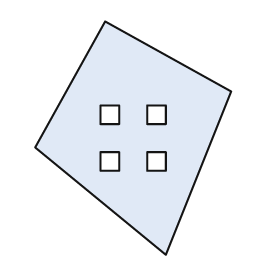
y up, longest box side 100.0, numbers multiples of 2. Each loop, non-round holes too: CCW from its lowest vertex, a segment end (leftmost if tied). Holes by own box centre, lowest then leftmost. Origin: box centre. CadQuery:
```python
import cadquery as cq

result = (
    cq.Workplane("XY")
    .moveTo(14.0, -50.0)
    .lineTo(42.0, 20.0)
    .lineTo(-12.0, 50.0)
    .lineTo(-42.0, -4.0)
    .close()
    .moveTo(-14.0, -14.0)
    .lineTo(-6.0, -14.0)
    .lineTo(-6.0, -6.0)
    .lineTo(-14.0, -6.0)
    .close()
    .moveTo(6.0, -14.0)
    .lineTo(14.0, -14.0)
    .lineTo(14.0, -6.0)
    .lineTo(6.0, -6.0)
    .close()
    .moveTo(-14.0, 6.0)
    .lineTo(-6.0, 6.0)
    .lineTo(-6.0, 14.0)
    .lineTo(-14.0, 14.0)
    .close()
    .moveTo(6.0, 6.0)
    .lineTo(14.0, 6.0)
    .lineTo(14.0, 14.0)
    .lineTo(6.0, 14.0)
    .close()
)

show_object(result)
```